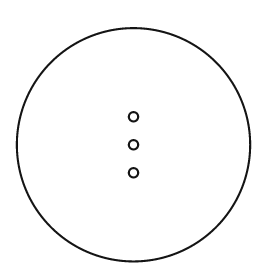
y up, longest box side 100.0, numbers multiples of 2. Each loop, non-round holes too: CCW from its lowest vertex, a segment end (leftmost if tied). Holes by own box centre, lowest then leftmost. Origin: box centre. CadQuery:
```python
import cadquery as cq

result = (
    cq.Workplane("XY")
    .moveTo(0.0, 0.0)
    .circle(50.0)
    .moveTo(0.0, -12.0)
    .circle(2.0)
    .moveTo(0.0, 0.0)
    .circle(2.0)
    .moveTo(0.0, 12.0)
    .circle(2.0)
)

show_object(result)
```